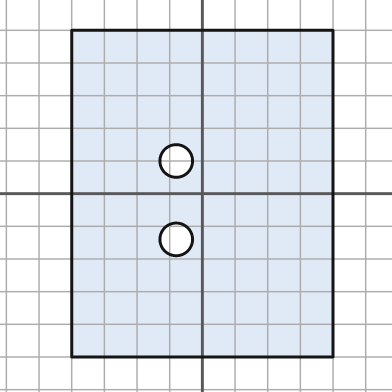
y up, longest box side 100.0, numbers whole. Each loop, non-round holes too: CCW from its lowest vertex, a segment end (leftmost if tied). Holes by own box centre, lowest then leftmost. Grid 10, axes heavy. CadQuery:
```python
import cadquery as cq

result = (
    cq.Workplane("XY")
    .moveTo(-40.0, -50.0)
    .lineTo(40.0, -50.0)
    .lineTo(40.0, 50.0)
    .lineTo(-40.0, 50.0)
    .close()
    .moveTo(-8.0, -14.0)
    .circle(5.0)
    .moveTo(-8.0, 10.0)
    .circle(5.0)
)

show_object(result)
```